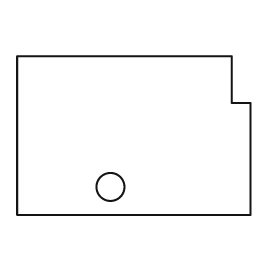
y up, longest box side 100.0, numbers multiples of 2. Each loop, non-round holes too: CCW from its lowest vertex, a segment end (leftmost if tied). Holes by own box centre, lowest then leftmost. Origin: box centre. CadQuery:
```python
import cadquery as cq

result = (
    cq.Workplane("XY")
    .moveTo(-50.0, -34.0)
    .lineTo(50.0, -34.0)
    .lineTo(50.0, 14.0)
    .lineTo(42.0, 14.0)
    .lineTo(42.0, 34.0)
    .lineTo(-50.0, 34.0)
    .close()
    .moveTo(-10.0, -22.0)
    .circle(6.0)
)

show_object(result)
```